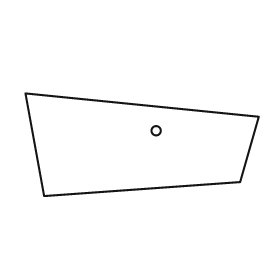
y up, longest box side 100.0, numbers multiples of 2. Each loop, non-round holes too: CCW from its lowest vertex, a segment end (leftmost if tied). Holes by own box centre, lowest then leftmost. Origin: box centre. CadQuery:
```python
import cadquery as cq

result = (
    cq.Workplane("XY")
    .moveTo(-42.0, -22.0)
    .lineTo(42.0, -16.0)
    .lineTo(50.0, 12.0)
    .lineTo(-50.0, 22.0)
    .close()
    .moveTo(6.0, 6.0)
    .circle(2.0)
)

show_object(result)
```